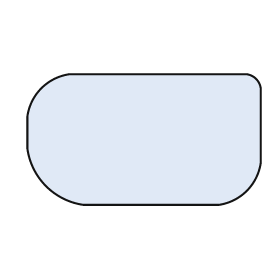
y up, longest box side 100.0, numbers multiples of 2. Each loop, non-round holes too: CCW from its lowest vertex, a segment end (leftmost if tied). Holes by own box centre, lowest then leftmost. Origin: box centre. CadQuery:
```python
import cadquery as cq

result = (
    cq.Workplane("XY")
    .moveTo(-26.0, -28.0)
    .lineTo(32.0, -28.0)
    .threePointArc((44.0, -22.0), (50.0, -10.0))
    .lineTo(50.0, 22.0)
    .threePointArc((48.0, 26.0), (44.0, 28.0))
    .lineTo(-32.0, 28.0)
    .threePointArc((-44.0, 22.0), (-50.0, 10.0))
    .lineTo(-50.0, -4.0)
    .threePointArc((-42.0, -20.0), (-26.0, -28.0))
    .close()
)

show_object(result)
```